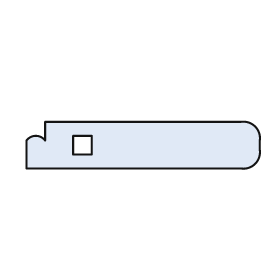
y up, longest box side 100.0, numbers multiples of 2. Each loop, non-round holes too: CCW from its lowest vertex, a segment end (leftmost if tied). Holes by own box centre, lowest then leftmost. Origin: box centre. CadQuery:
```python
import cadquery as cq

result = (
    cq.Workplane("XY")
    .moveTo(-50.0, -10.0)
    .lineTo(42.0, -10.0)
    .threePointArc((48.0, -8.0), (50.0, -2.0))
    .lineTo(50.0, 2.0)
    .threePointArc((48.0, 8.0), (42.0, 10.0))
    .lineTo(-42.0, 10.0)
    .lineTo(-42.0, 2.0)
    .threePointArc((-46.0, 4.0), (-50.0, 2.0))
    .close()
    .moveTo(-30.0, -4.0)
    .lineTo(-22.0, -4.0)
    .lineTo(-22.0, 4.0)
    .lineTo(-30.0, 4.0)
    .close()
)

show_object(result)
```